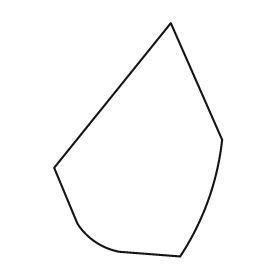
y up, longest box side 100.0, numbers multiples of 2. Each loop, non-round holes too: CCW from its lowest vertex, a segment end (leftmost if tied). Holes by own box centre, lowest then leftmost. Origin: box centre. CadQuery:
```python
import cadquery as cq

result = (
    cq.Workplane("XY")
    .moveTo(18.0, -50.0)
    .threePointArc((30.0, -26.0), (36.0, 0.0))
    .lineTo(14.0, 50.0)
    .lineTo(-36.0, -12.0)
    .lineTo(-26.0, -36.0)
    .threePointArc((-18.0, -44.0), (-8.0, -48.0))
    .close()
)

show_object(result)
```